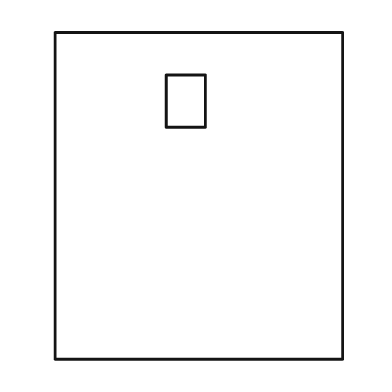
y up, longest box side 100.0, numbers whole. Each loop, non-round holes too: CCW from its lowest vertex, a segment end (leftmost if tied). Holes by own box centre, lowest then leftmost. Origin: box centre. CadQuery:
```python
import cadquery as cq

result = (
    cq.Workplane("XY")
    .moveTo(-44.0, -50.0)
    .lineTo(44.0, -50.0)
    .lineTo(44.0, 50.0)
    .lineTo(-44.0, 50.0)
    .close()
    .moveTo(-10.0, 21.0)
    .lineTo(2.0, 21.0)
    .lineTo(2.0, 37.0)
    .lineTo(-10.0, 37.0)
    .close()
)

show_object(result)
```